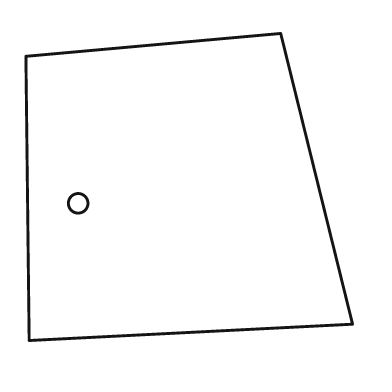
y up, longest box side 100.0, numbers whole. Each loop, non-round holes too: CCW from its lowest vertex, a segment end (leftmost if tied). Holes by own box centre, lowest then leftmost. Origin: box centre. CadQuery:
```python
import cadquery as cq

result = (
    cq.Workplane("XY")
    .moveTo(-49.0, -47.0)
    .lineTo(50.0, -42.0)
    .lineTo(28.0, 47.0)
    .lineTo(-50.0, 40.0)
    .close()
    .moveTo(-34.0, -5.0)
    .circle(3.0)
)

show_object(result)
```